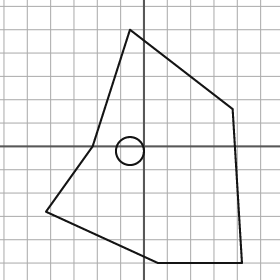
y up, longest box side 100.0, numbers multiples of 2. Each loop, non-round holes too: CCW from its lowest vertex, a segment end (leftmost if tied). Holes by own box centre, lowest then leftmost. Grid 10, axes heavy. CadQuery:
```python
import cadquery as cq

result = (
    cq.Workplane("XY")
    .moveTo(6.0, -50.0)
    .lineTo(42.0, -50.0)
    .lineTo(38.0, 16.0)
    .lineTo(-6.0, 50.0)
    .lineTo(-22.0, 0.0)
    .lineTo(-42.0, -28.0)
    .close()
    .moveTo(-6.0, -2.0)
    .circle(6.0)
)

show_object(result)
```